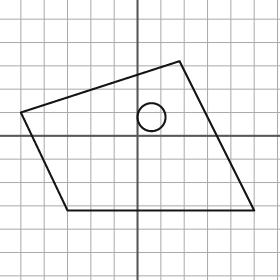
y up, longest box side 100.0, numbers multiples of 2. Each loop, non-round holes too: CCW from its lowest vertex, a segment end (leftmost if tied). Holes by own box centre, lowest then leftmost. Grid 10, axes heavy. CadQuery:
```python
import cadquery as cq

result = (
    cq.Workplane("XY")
    .moveTo(-30.0, -32.0)
    .lineTo(50.0, -32.0)
    .lineTo(18.0, 32.0)
    .lineTo(-50.0, 10.0)
    .close()
    .moveTo(6.0, 8.0)
    .circle(6.0)
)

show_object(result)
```